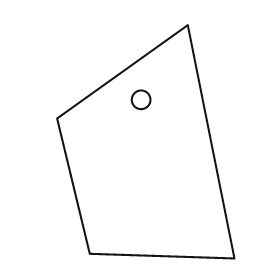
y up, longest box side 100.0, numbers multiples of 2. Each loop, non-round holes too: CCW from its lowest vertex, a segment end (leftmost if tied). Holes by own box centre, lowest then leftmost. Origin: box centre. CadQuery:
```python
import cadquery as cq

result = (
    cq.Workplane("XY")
    .moveTo(38.0, -50.0)
    .lineTo(18.0, 50.0)
    .lineTo(-38.0, 10.0)
    .lineTo(-24.0, -48.0)
    .close()
    .moveTo(-2.0, 18.0)
    .circle(4.0)
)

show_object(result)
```